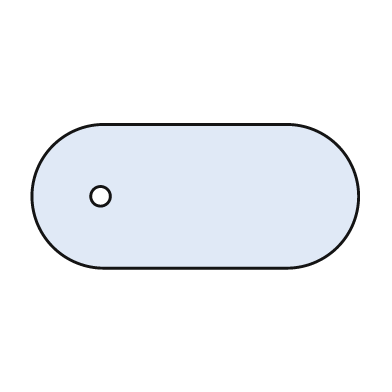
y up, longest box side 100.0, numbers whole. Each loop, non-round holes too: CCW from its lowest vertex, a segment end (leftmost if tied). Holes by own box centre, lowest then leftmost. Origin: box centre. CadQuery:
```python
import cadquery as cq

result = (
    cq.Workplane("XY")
    .moveTo(-28.0, -22.0)
    .lineTo(28.0, -22.0)
    .threePointArc((50.0, 0.0), (28.0, 22.0))
    .lineTo(-28.0, 22.0)
    .threePointArc((-50.0, 0.0), (-28.0, -22.0))
    .close()
    .moveTo(-29.0, 0.0)
    .circle(3.0)
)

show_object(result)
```